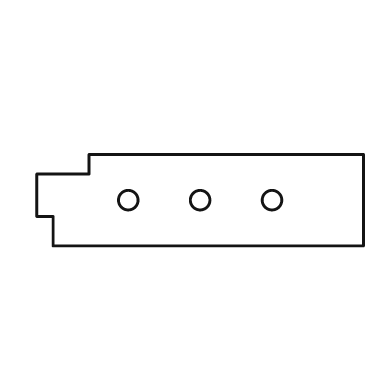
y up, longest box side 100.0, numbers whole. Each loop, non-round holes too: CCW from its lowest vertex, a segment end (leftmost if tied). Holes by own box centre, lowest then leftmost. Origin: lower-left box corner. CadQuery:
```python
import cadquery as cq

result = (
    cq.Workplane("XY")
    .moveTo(5.0, 0.0)
    .lineTo(100.0, 0.0)
    .lineTo(100.0, 28.0)
    .lineTo(16.0, 28.0)
    .lineTo(16.0, 22.0)
    .lineTo(0.0, 22.0)
    .lineTo(0.0, 9.0)
    .lineTo(5.0, 9.0)
    .close()
    .moveTo(28.0, 14.0)
    .circle(3.0)
    .moveTo(50.0, 14.0)
    .circle(3.0)
    .moveTo(72.0, 14.0)
    .circle(3.0)
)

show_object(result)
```